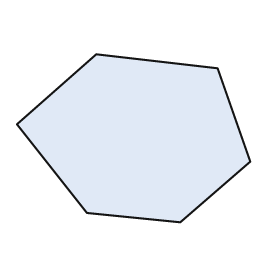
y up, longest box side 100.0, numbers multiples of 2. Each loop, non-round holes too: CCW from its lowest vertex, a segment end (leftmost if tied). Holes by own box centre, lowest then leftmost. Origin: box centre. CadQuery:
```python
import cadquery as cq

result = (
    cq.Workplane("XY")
    .moveTo(20.0, -36.0)
    .lineTo(50.0, -10.0)
    .lineTo(36.0, 30.0)
    .lineTo(-16.0, 36.0)
    .lineTo(-50.0, 6.0)
    .lineTo(-20.0, -32.0)
    .close()
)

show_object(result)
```